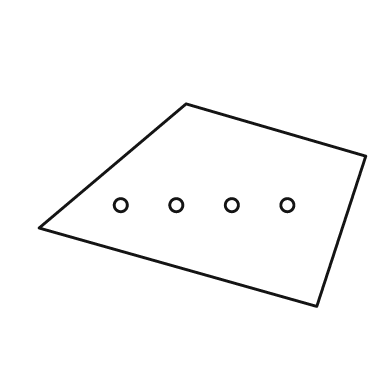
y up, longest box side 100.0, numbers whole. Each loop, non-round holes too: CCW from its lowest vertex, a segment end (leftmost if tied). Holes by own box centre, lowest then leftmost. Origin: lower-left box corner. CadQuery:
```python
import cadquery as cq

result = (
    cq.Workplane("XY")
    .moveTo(85.0, 0.0)
    .lineTo(100.0, 46.0)
    .lineTo(45.0, 62.0)
    .lineTo(0.0, 24.0)
    .close()
    .moveTo(25.0, 31.0)
    .circle(2.0)
    .moveTo(42.0, 31.0)
    .circle(2.0)
    .moveTo(59.0, 31.0)
    .circle(2.0)
    .moveTo(76.0, 31.0)
    .circle(2.0)
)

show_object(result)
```